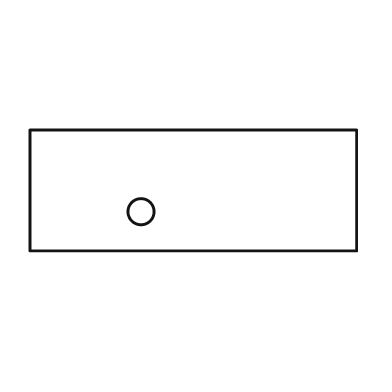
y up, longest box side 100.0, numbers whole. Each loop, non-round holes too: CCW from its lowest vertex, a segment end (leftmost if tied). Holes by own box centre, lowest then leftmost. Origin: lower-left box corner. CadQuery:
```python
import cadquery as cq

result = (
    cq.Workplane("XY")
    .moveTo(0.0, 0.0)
    .lineTo(100.0, 0.0)
    .lineTo(100.0, 37.0)
    .lineTo(0.0, 37.0)
    .close()
    .moveTo(34.0, 12.0)
    .circle(4.0)
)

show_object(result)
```